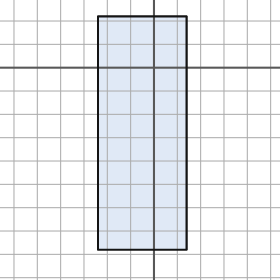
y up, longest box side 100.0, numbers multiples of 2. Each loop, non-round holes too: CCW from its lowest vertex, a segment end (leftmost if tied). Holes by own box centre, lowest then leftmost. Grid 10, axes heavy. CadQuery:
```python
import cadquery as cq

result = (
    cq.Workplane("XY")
    .moveTo(-24.0, -78.0)
    .lineTo(14.0, -78.0)
    .lineTo(14.0, 22.0)
    .lineTo(-24.0, 22.0)
    .close()
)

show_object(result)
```